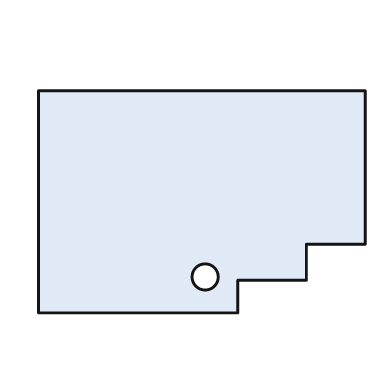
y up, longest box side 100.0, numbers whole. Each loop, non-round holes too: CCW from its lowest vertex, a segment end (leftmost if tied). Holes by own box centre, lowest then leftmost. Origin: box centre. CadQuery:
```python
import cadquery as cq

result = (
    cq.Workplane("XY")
    .moveTo(-50.0, -34.0)
    .lineTo(11.0, -34.0)
    .lineTo(11.0, -24.0)
    .lineTo(32.0, -24.0)
    .lineTo(32.0, -13.0)
    .lineTo(50.0, -13.0)
    .lineTo(50.0, 34.0)
    .lineTo(-50.0, 34.0)
    .close()
    .moveTo(1.0, -23.0)
    .circle(4.0)
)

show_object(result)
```